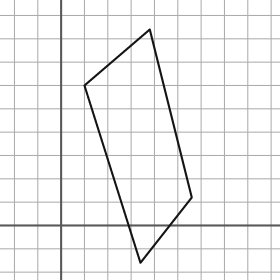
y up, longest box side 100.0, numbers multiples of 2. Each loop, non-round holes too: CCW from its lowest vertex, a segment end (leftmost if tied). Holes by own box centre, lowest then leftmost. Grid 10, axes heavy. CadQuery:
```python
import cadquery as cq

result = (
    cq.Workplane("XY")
    .moveTo(34.0, -16.0)
    .lineTo(56.0, 12.0)
    .lineTo(38.0, 84.0)
    .lineTo(10.0, 60.0)
    .close()
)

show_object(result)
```